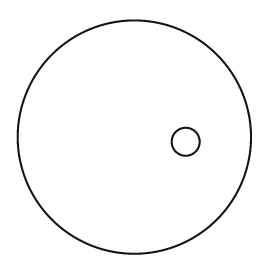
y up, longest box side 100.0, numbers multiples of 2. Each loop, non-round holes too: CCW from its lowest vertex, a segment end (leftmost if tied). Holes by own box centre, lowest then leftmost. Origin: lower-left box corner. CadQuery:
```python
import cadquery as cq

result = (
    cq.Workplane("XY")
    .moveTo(50.0, 50.0)
    .circle(50.0)
    .moveTo(72.0, 48.0)
    .circle(6.0)
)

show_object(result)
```